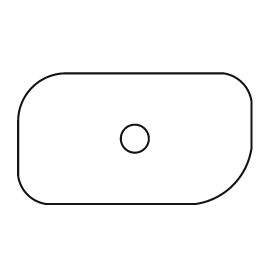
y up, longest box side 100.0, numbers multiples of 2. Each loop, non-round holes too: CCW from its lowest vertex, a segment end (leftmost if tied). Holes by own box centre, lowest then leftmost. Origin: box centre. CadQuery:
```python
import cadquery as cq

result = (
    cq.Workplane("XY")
    .moveTo(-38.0, -28.0)
    .lineTo(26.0, -28.0)
    .threePointArc((42.0, -20.0), (50.0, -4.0))
    .lineTo(50.0, 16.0)
    .threePointArc((46.0, 24.0), (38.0, 28.0))
    .lineTo(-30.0, 28.0)
    .threePointArc((-44.0, 22.0), (-50.0, 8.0))
    .lineTo(-50.0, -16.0)
    .threePointArc((-46.0, -24.0), (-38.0, -28.0))
    .close()
    .moveTo(0.0, 0.0)
    .circle(6.0)
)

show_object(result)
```